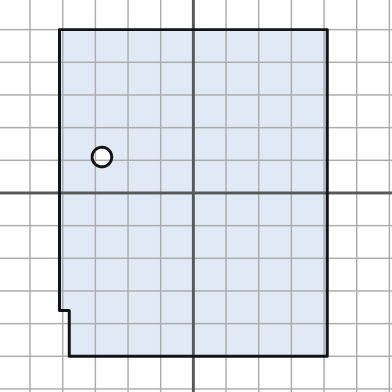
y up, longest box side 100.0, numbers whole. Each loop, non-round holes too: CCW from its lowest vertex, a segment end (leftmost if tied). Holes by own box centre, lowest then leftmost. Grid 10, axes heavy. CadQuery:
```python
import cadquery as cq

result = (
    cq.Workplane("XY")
    .moveTo(-38.0, -50.0)
    .lineTo(41.0, -50.0)
    .lineTo(41.0, 50.0)
    .lineTo(-41.0, 50.0)
    .lineTo(-41.0, -36.0)
    .lineTo(-38.0, -36.0)
    .close()
    .moveTo(-28.0, 11.0)
    .circle(3.0)
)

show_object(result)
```